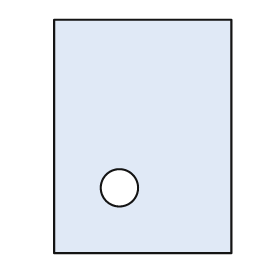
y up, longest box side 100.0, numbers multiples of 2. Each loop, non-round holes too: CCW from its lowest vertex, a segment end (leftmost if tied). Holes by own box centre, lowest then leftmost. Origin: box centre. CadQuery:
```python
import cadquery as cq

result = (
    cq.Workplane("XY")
    .moveTo(-38.0, -50.0)
    .lineTo(38.0, -50.0)
    .lineTo(38.0, 50.0)
    .lineTo(-38.0, 50.0)
    .close()
    .moveTo(-10.0, -22.0)
    .circle(8.0)
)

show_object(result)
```